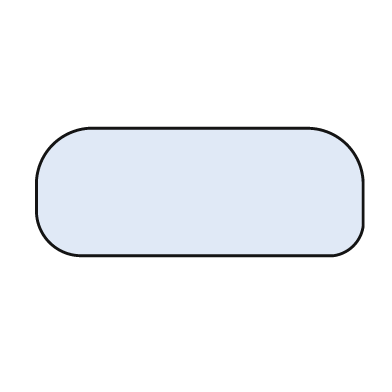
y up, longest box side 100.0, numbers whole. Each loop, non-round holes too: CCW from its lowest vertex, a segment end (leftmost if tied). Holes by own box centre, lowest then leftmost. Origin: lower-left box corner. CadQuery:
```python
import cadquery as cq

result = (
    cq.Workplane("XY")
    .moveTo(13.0, 0.0)
    .lineTo(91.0, 0.0)
    .threePointArc((97.0, 3.0), (100.0, 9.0))
    .lineTo(100.0, 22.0)
    .threePointArc((95.0, 34.0), (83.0, 39.0))
    .lineTo(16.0, 39.0)
    .threePointArc((5.0, 34.0), (0.0, 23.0))
    .lineTo(0.0, 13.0)
    .threePointArc((4.0, 4.0), (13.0, 0.0))
    .close()
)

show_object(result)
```